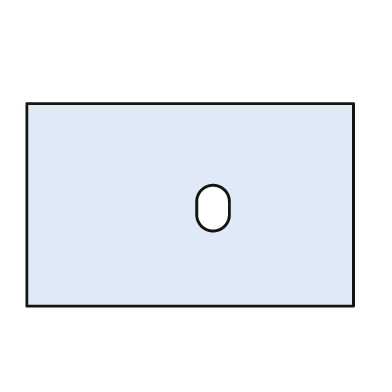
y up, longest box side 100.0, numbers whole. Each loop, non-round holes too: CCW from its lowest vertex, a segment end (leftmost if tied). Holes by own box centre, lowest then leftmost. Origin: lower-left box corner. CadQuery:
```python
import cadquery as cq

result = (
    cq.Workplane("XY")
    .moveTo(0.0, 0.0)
    .lineTo(100.0, 0.0)
    .lineTo(100.0, 62.0)
    .lineTo(0.0, 62.0)
    .close()
    .moveTo(52.0, 28.0)
    .threePointArc((57.0, 23.0), (62.0, 28.0))
    .lineTo(62.0, 32.0)
    .threePointArc((57.0, 37.0), (52.0, 32.0))
    .close()
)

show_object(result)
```